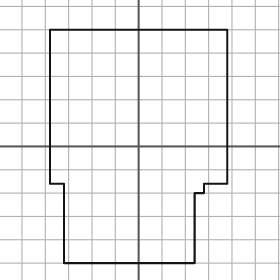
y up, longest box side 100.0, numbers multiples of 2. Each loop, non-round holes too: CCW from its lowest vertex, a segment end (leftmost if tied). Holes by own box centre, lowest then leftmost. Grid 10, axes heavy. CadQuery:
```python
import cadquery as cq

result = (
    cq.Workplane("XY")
    .moveTo(-32.0, -50.0)
    .lineTo(24.0, -50.0)
    .lineTo(24.0, -20.0)
    .lineTo(28.0, -20.0)
    .lineTo(28.0, -16.0)
    .lineTo(38.0, -16.0)
    .lineTo(38.0, 50.0)
    .lineTo(-38.0, 50.0)
    .lineTo(-38.0, -16.0)
    .lineTo(-32.0, -16.0)
    .close()
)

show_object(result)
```